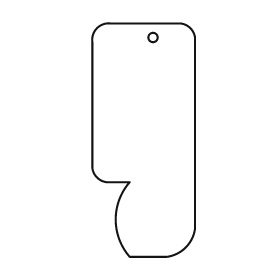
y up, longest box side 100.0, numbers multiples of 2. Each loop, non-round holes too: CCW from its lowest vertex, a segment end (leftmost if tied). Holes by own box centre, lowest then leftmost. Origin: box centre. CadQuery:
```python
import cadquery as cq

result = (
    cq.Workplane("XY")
    .moveTo(-6.0, -50.0)
    .lineTo(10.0, -50.0)
    .threePointArc((18.0, -46.0), (22.0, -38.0))
    .lineTo(22.0, 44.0)
    .threePointArc((20.0, 48.0), (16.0, 50.0))
    .lineTo(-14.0, 50.0)
    .threePointArc((-20.0, 48.0), (-22.0, 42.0))
    .lineTo(-22.0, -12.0)
    .threePointArc((-20.0, -16.0), (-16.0, -18.0))
    .lineTo(-6.0, -18.0)
    .threePointArc((-12.0, -34.0), (-6.0, -50.0))
    .close()
    .moveTo(4.0, 44.0)
    .circle(2.0)
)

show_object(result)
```